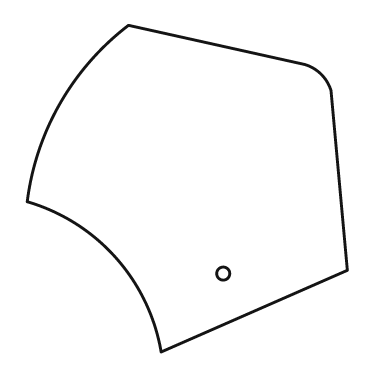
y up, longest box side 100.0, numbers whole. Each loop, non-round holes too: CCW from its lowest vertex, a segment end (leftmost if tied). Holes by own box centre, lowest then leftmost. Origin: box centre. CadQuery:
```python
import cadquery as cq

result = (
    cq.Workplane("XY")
    .moveTo(-8.0, -50.0)
    .lineTo(49.0, -25.0)
    .lineTo(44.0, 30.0)
    .threePointArc((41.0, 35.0), (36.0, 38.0))
    .lineTo(-18.0, 50.0)
    .threePointArc((-39.0, 26.0), (-49.0, -4.0))
    .threePointArc((-22.0, -21.0), (-8.0, -50.0))
    .close()
    .moveTo(11.0, -26.0)
    .circle(2.0)
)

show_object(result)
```